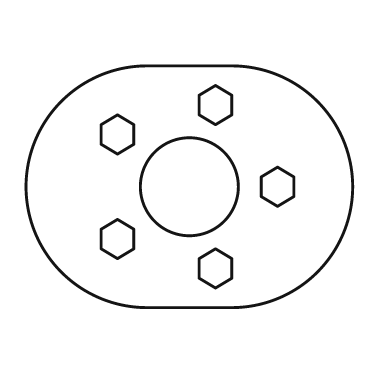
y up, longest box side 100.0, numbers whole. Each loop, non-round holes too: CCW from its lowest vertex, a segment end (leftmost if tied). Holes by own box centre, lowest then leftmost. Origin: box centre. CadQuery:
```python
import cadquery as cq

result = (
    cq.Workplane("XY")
    .moveTo(-13.0, -37.0)
    .lineTo(13.0, -37.0)
    .threePointArc((50.0, 0.0), (13.0, 37.0))
    .lineTo(-13.0, 37.0)
    .threePointArc((-50.0, 0.0), (-13.0, -37.0))
    .close()
    .moveTo(8.0, -31.0)
    .lineTo(13.0, -28.0)
    .lineTo(13.0, -22.0)
    .lineTo(8.0, -19.0)
    .lineTo(3.0, -22.0)
    .lineTo(3.0, -28.0)
    .close()
    .moveTo(-22.0, -22.0)
    .lineTo(-17.0, -19.0)
    .lineTo(-17.0, -13.0)
    .lineTo(-22.0, -10.0)
    .lineTo(-27.0, -13.0)
    .lineTo(-27.0, -19.0)
    .close()
    .moveTo(0.0, 0.0)
    .circle(15.0)
    .moveTo(27.0, -6.0)
    .lineTo(32.0, -3.0)
    .lineTo(32.0, 3.0)
    .lineTo(27.0, 6.0)
    .lineTo(22.0, 3.0)
    .lineTo(22.0, -3.0)
    .close()
    .moveTo(-22.0, 10.0)
    .lineTo(-17.0, 13.0)
    .lineTo(-17.0, 19.0)
    .lineTo(-22.0, 22.0)
    .lineTo(-27.0, 19.0)
    .lineTo(-27.0, 13.0)
    .close()
    .moveTo(8.0, 19.0)
    .lineTo(13.0, 22.0)
    .lineTo(13.0, 28.0)
    .lineTo(8.0, 31.0)
    .lineTo(3.0, 28.0)
    .lineTo(3.0, 22.0)
    .close()
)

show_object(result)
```